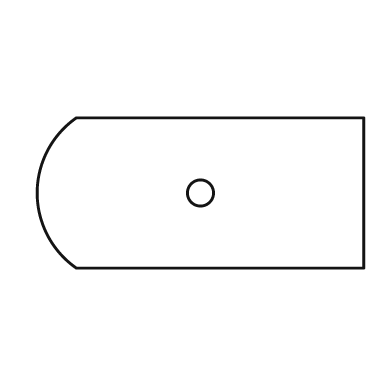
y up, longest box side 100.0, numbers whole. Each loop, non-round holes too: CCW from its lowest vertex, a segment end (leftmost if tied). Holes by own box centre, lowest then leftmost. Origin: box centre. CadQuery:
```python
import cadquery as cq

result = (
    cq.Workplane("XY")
    .moveTo(-38.0, -23.0)
    .lineTo(50.0, -23.0)
    .lineTo(50.0, 23.0)
    .lineTo(-38.0, 23.0)
    .threePointArc((-50.0, 0.0), (-38.0, -23.0))
    .close()
    .moveTo(0.0, 0.0)
    .circle(4.0)
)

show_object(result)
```